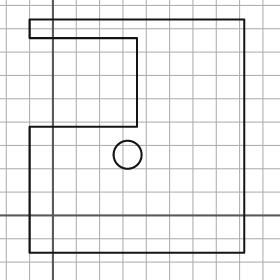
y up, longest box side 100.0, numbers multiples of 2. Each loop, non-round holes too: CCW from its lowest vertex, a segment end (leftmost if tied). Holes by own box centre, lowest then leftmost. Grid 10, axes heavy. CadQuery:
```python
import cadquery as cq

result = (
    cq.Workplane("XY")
    .moveTo(-10.0, -16.0)
    .lineTo(82.0, -16.0)
    .lineTo(82.0, 84.0)
    .lineTo(-10.0, 84.0)
    .lineTo(-10.0, 76.0)
    .lineTo(36.0, 76.0)
    .lineTo(36.0, 38.0)
    .lineTo(-10.0, 38.0)
    .close()
    .moveTo(32.0, 26.0)
    .circle(6.0)
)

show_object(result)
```